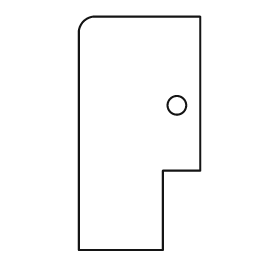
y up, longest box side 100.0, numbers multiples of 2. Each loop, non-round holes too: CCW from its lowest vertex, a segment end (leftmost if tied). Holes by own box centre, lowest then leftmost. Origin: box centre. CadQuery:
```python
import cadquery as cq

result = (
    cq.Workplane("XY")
    .moveTo(-26.0, -50.0)
    .lineTo(10.0, -50.0)
    .lineTo(10.0, -16.0)
    .lineTo(26.0, -16.0)
    .lineTo(26.0, 50.0)
    .lineTo(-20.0, 50.0)
    .threePointArc((-24.0, 48.0), (-26.0, 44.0))
    .close()
    .moveTo(16.0, 12.0)
    .circle(4.0)
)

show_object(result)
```